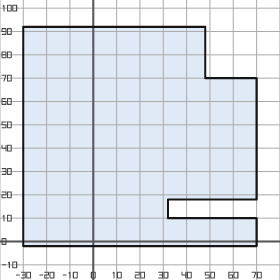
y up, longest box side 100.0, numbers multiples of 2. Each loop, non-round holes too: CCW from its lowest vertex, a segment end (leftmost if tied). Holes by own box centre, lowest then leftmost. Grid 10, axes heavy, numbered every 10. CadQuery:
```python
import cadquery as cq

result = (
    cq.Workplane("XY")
    .moveTo(-30.0, -2.0)
    .lineTo(70.0, -2.0)
    .lineTo(70.0, 10.0)
    .lineTo(32.0, 10.0)
    .lineTo(32.0, 18.0)
    .lineTo(70.0, 18.0)
    .lineTo(70.0, 70.0)
    .lineTo(48.0, 70.0)
    .lineTo(48.0, 92.0)
    .lineTo(-30.0, 92.0)
    .close()
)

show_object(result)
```